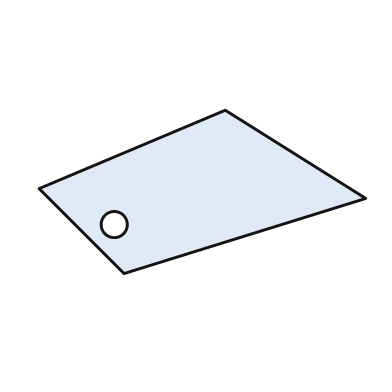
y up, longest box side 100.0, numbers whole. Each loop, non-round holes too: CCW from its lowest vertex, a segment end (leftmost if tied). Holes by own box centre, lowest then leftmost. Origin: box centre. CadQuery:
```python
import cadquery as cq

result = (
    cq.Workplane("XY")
    .moveTo(-24.0, -25.0)
    .lineTo(50.0, -2.0)
    .lineTo(7.0, 25.0)
    .lineTo(-50.0, 1.0)
    .close()
    .moveTo(-27.0, -10.0)
    .circle(4.0)
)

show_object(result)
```